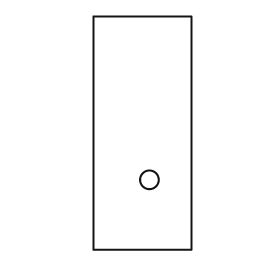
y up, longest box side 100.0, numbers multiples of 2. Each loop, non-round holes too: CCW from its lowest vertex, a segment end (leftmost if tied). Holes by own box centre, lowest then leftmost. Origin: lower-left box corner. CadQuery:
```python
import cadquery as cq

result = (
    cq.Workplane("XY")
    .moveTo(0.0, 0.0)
    .lineTo(42.0, 0.0)
    .lineTo(42.0, 100.0)
    .lineTo(0.0, 100.0)
    .close()
    .moveTo(24.0, 30.0)
    .circle(4.0)
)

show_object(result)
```